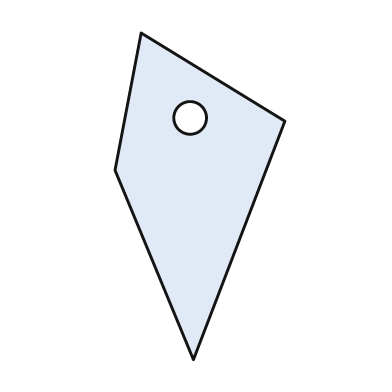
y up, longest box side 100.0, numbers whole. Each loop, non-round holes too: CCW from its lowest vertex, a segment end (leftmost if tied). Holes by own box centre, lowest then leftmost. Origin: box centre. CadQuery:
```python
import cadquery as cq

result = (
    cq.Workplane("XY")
    .moveTo(-2.0, -50.0)
    .lineTo(26.0, 23.0)
    .lineTo(-18.0, 50.0)
    .lineTo(-26.0, 8.0)
    .close()
    .moveTo(-3.0, 24.0)
    .circle(5.0)
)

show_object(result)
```